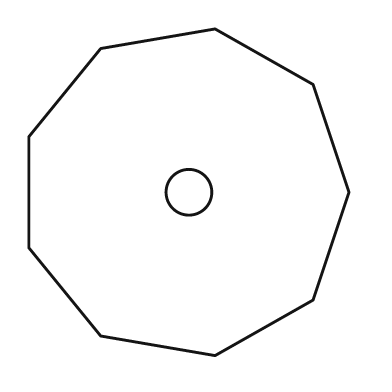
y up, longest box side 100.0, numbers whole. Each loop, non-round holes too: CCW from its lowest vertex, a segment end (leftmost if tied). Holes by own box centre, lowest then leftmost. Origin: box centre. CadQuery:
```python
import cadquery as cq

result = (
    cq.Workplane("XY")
    .moveTo(8.0, -50.0)
    .lineTo(38.0, -33.0)
    .lineTo(49.0, 0.0)
    .lineTo(38.0, 33.0)
    .lineTo(8.0, 50.0)
    .lineTo(-27.0, 44.0)
    .lineTo(-49.0, 17.0)
    .lineTo(-49.0, -17.0)
    .lineTo(-27.0, -44.0)
    .close()
    .moveTo(0.0, 0.0)
    .circle(7.0)
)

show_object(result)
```